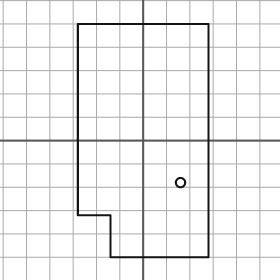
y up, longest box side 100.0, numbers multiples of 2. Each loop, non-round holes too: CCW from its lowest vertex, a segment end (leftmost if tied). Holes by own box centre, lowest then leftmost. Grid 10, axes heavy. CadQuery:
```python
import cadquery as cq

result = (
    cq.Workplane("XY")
    .moveTo(-14.0, -50.0)
    .lineTo(28.0, -50.0)
    .lineTo(28.0, 50.0)
    .lineTo(-28.0, 50.0)
    .lineTo(-28.0, -32.0)
    .lineTo(-14.0, -32.0)
    .close()
    .moveTo(16.0, -18.0)
    .circle(2.0)
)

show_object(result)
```